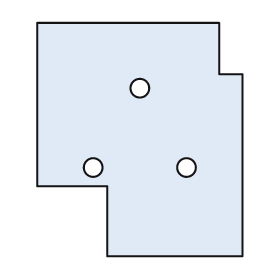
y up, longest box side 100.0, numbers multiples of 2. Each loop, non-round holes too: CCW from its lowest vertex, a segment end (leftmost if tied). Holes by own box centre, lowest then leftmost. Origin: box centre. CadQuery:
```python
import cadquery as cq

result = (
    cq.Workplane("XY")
    .moveTo(-14.0, -50.0)
    .lineTo(44.0, -50.0)
    .lineTo(44.0, 28.0)
    .lineTo(34.0, 28.0)
    .lineTo(34.0, 50.0)
    .lineTo(-44.0, 50.0)
    .lineTo(-44.0, -20.0)
    .lineTo(-14.0, -20.0)
    .close()
    .moveTo(-20.0, -12.0)
    .circle(4.0)
    .moveTo(20.0, -12.0)
    .circle(4.0)
    .moveTo(0.0, 22.0)
    .circle(4.0)
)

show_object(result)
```